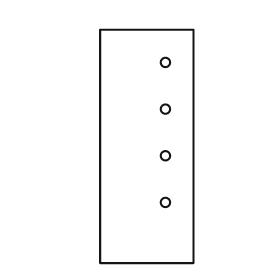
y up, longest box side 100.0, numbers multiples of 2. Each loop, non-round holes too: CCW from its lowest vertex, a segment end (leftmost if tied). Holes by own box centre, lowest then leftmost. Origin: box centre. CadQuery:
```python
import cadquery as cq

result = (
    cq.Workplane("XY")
    .moveTo(-20.0, -50.0)
    .lineTo(20.0, -50.0)
    .lineTo(20.0, 50.0)
    .lineTo(-20.0, 50.0)
    .close()
    .moveTo(8.0, -24.0)
    .circle(2.0)
    .moveTo(8.0, -4.0)
    .circle(2.0)
    .moveTo(8.0, 16.0)
    .circle(2.0)
    .moveTo(8.0, 36.0)
    .circle(2.0)
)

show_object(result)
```